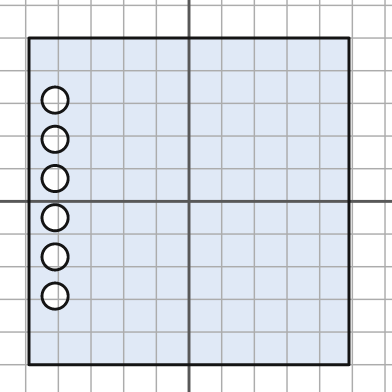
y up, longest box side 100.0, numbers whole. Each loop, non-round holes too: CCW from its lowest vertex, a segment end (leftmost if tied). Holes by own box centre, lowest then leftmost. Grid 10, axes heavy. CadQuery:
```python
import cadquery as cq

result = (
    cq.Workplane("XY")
    .moveTo(-49.0, -50.0)
    .lineTo(49.0, -50.0)
    .lineTo(49.0, 50.0)
    .lineTo(-49.0, 50.0)
    .close()
    .moveTo(-41.0, -29.0)
    .circle(4.0)
    .moveTo(-41.0, -17.0)
    .circle(4.0)
    .moveTo(-41.0, -5.0)
    .circle(4.0)
    .moveTo(-41.0, 7.0)
    .circle(4.0)
    .moveTo(-41.0, 19.0)
    .circle(4.0)
    .moveTo(-41.0, 31.0)
    .circle(4.0)
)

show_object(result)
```